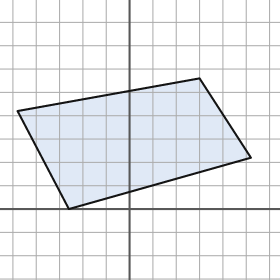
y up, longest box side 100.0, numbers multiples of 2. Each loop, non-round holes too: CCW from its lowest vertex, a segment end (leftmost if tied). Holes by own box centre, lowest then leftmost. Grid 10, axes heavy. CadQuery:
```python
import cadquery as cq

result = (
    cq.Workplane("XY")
    .moveTo(-26.0, 0.0)
    .lineTo(52.0, 22.0)
    .lineTo(30.0, 56.0)
    .lineTo(-48.0, 42.0)
    .close()
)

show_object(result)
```